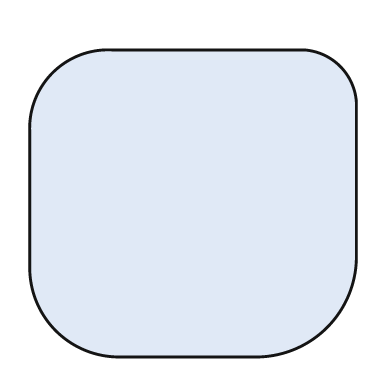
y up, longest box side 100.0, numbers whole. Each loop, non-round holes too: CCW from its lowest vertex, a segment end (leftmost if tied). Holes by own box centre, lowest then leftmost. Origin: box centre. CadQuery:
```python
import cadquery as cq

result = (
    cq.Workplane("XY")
    .moveTo(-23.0, -47.0)
    .lineTo(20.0, -47.0)
    .threePointArc((41.0, -38.0), (50.0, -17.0))
    .lineTo(50.0, 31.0)
    .threePointArc((45.0, 42.0), (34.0, 47.0))
    .lineTo(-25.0, 47.0)
    .threePointArc((-43.0, 40.0), (-50.0, 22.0))
    .lineTo(-50.0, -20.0)
    .threePointArc((-42.0, -39.0), (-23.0, -47.0))
    .close()
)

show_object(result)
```